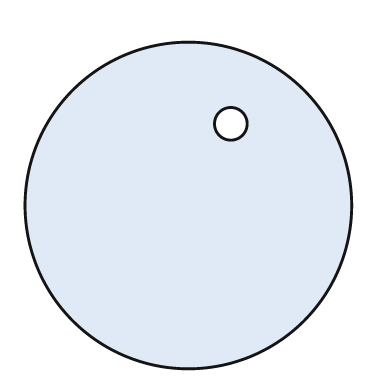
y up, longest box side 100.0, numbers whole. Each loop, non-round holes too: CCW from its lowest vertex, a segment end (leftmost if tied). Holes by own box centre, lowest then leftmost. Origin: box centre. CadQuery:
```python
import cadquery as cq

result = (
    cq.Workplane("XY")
    .moveTo(0.0, 0.0)
    .circle(50.0)
    .moveTo(13.0, 25.0)
    .circle(5.0)
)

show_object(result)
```